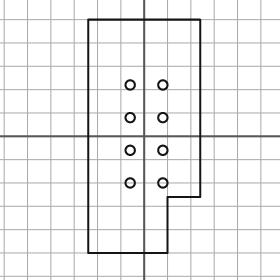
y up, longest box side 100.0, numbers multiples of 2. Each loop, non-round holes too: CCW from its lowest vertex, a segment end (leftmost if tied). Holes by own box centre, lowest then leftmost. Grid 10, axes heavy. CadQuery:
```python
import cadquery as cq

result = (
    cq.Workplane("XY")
    .moveTo(-24.0, -50.0)
    .lineTo(10.0, -50.0)
    .lineTo(10.0, -26.0)
    .lineTo(24.0, -26.0)
    .lineTo(24.0, 50.0)
    .lineTo(-24.0, 50.0)
    .close()
    .moveTo(-6.0, -20.0)
    .circle(2.0)
    .moveTo(8.0, -20.0)
    .circle(2.0)
    .moveTo(-6.0, -6.0)
    .circle(2.0)
    .moveTo(8.0, -6.0)
    .circle(2.0)
    .moveTo(-6.0, 8.0)
    .circle(2.0)
    .moveTo(8.0, 8.0)
    .circle(2.0)
    .moveTo(-6.0, 22.0)
    .circle(2.0)
    .moveTo(8.0, 22.0)
    .circle(2.0)
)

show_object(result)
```